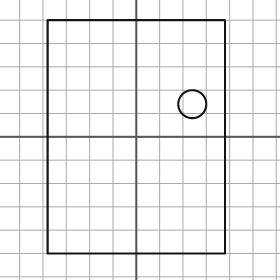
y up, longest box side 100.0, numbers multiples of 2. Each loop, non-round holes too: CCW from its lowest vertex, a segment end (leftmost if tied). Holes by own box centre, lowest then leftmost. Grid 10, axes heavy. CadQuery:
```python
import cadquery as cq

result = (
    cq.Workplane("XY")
    .moveTo(-38.0, -50.0)
    .lineTo(38.0, -50.0)
    .lineTo(38.0, 50.0)
    .lineTo(-38.0, 50.0)
    .close()
    .moveTo(24.0, 14.0)
    .circle(6.0)
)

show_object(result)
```